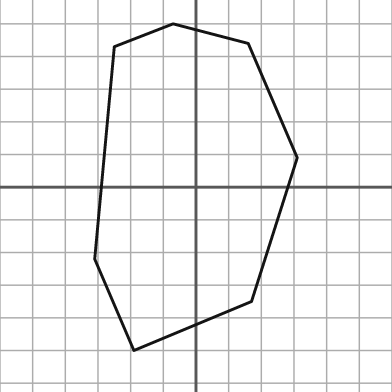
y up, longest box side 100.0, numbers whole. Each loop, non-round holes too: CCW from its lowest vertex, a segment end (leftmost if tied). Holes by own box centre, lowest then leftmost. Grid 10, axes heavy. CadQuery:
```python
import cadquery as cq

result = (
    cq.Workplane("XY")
    .moveTo(-19.0, -50.0)
    .lineTo(17.0, -35.0)
    .lineTo(31.0, 9.0)
    .lineTo(16.0, 44.0)
    .lineTo(-7.0, 50.0)
    .lineTo(-25.0, 43.0)
    .lineTo(-31.0, -22.0)
    .close()
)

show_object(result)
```